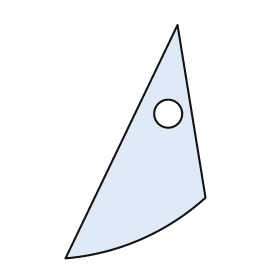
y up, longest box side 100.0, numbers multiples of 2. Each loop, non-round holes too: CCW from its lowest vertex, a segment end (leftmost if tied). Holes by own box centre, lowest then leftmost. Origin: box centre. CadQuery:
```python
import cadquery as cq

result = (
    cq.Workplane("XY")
    .moveTo(-30.0, -50.0)
    .threePointArc((2.0, -42.0), (30.0, -24.0))
    .lineTo(18.0, 50.0)
    .close()
    .moveTo(14.0, 12.0)
    .circle(6.0)
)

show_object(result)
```